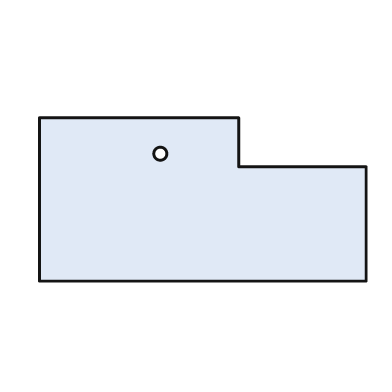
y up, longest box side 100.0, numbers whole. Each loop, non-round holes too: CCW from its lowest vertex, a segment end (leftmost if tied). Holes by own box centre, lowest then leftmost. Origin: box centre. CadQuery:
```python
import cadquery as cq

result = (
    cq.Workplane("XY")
    .moveTo(-50.0, -25.0)
    .lineTo(50.0, -25.0)
    .lineTo(50.0, 10.0)
    .lineTo(11.0, 10.0)
    .lineTo(11.0, 25.0)
    .lineTo(-50.0, 25.0)
    .close()
    .moveTo(-13.0, 14.0)
    .circle(2.0)
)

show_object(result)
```